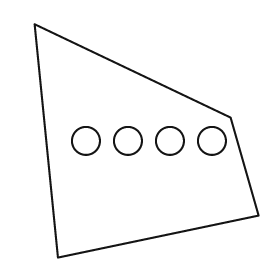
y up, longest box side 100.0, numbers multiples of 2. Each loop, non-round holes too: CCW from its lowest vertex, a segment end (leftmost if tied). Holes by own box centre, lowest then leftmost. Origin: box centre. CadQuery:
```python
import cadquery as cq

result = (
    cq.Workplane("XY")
    .moveTo(-38.0, -50.0)
    .lineTo(48.0, -32.0)
    .lineTo(36.0, 10.0)
    .lineTo(-48.0, 50.0)
    .close()
    .moveTo(-26.0, 0.0)
    .circle(6.0)
    .moveTo(-8.0, 0.0)
    .circle(6.0)
    .moveTo(10.0, 0.0)
    .circle(6.0)
    .moveTo(28.0, 0.0)
    .circle(6.0)
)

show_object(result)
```